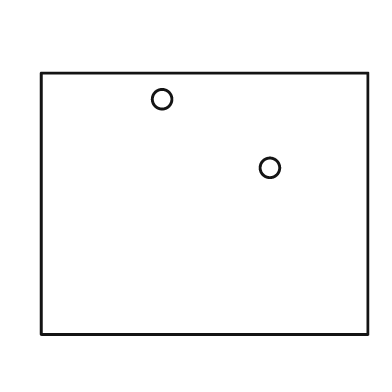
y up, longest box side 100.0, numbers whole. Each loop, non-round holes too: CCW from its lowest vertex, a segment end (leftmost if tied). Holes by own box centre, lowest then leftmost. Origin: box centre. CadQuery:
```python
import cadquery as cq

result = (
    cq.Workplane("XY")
    .moveTo(-50.0, -40.0)
    .lineTo(50.0, -40.0)
    .lineTo(50.0, 40.0)
    .lineTo(-50.0, 40.0)
    .close()
    .moveTo(20.0, 11.0)
    .circle(3.0)
    .moveTo(-13.0, 32.0)
    .circle(3.0)
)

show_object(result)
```